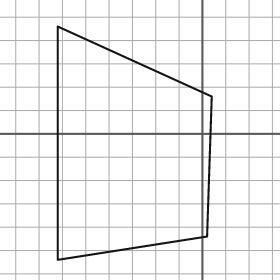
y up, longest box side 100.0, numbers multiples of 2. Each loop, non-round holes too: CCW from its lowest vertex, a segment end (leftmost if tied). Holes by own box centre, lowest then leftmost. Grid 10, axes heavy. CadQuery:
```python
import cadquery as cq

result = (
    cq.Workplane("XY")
    .moveTo(-62.0, -54.0)
    .lineTo(2.0, -44.0)
    .lineTo(4.0, 16.0)
    .lineTo(-62.0, 46.0)
    .close()
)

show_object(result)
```